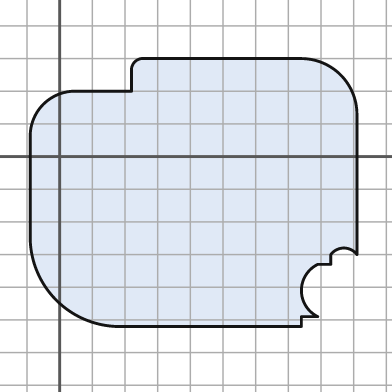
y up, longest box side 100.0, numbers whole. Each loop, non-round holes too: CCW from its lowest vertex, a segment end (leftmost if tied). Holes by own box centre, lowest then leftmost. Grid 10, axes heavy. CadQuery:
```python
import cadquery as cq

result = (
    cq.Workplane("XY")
    .moveTo(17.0, -52.0)
    .lineTo(74.0, -52.0)
    .lineTo(74.0, -49.0)
    .lineTo(79.0, -49.0)
    .threePointArc((74.0, -41.0), (79.0, -33.0))
    .lineTo(83.0, -33.0)
    .lineTo(83.0, -30.0)
    .threePointArc((87.0, -28.0), (91.0, -30.0))
    .lineTo(91.0, 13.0)
    .threePointArc((86.0, 25.0), (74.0, 30.0))
    .lineTo(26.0, 30.0)
    .threePointArc((23.0, 29.0), (22.0, 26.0))
    .lineTo(22.0, 20.0)
    .lineTo(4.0, 20.0)
    .threePointArc((-5.0, 16.0), (-9.0, 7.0))
    .lineTo(-9.0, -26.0)
    .threePointArc((-1.0, -44.0), (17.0, -52.0))
    .close()
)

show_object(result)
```